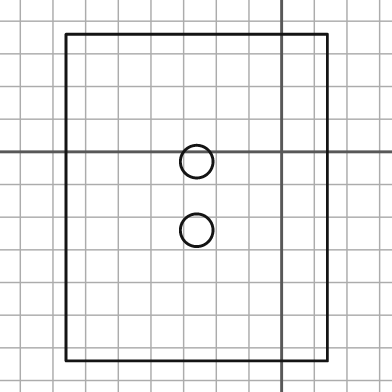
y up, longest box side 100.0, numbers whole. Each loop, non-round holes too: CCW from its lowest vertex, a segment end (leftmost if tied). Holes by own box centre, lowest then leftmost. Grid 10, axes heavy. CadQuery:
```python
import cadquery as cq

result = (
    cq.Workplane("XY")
    .moveTo(-66.0, -64.0)
    .lineTo(14.0, -64.0)
    .lineTo(14.0, 36.0)
    .lineTo(-66.0, 36.0)
    .close()
    .moveTo(-26.0, -24.0)
    .circle(5.0)
    .moveTo(-26.0, -3.0)
    .circle(5.0)
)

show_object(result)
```